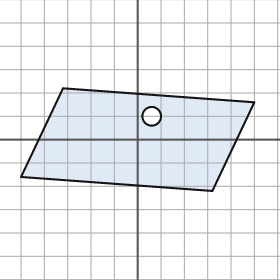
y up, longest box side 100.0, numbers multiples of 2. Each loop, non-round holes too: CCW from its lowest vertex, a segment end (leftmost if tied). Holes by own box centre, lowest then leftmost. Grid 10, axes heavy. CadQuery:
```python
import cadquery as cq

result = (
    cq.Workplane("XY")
    .moveTo(32.0, -22.0)
    .lineTo(50.0, 16.0)
    .lineTo(-32.0, 22.0)
    .lineTo(-50.0, -16.0)
    .close()
    .moveTo(6.0, 10.0)
    .circle(4.0)
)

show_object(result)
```